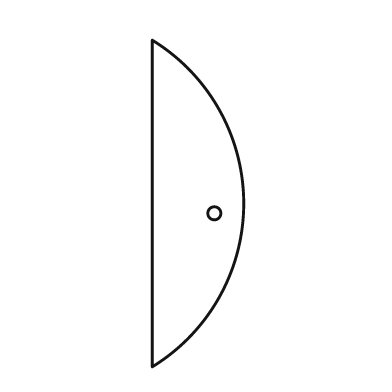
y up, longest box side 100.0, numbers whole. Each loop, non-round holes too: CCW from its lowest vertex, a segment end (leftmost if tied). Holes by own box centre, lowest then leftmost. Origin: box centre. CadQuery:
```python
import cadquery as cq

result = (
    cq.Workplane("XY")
    .moveTo(-14.0, -50.0)
    .threePointArc((14.0, 0.0), (-14.0, 50.0))
    .close()
    .moveTo(5.0, -3.0)
    .circle(2.0)
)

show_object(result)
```